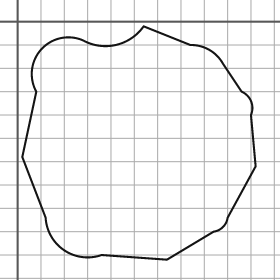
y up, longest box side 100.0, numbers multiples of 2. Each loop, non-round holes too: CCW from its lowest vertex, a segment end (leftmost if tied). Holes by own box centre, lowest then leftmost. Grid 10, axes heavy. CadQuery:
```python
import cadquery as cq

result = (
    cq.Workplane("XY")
    .moveTo(64.0, -102.0)
    .lineTo(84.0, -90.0)
    .threePointArc((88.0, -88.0), (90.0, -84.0))
    .lineTo(102.0, -62.0)
    .lineTo(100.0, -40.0)
    .threePointArc((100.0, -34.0), (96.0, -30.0))
    .lineTo(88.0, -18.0)
    .threePointArc((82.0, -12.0), (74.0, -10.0))
    .lineTo(54.0, -2.0)
    .threePointArc((42.0, -10.0), (28.0, -8.0))
    .threePointArc((10.0, -12.0), (8.0, -30.0))
    .lineTo(2.0, -58.0)
    .lineTo(12.0, -84.0)
    .threePointArc((20.0, -98.0), (36.0, -100.0))
    .close()
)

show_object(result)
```